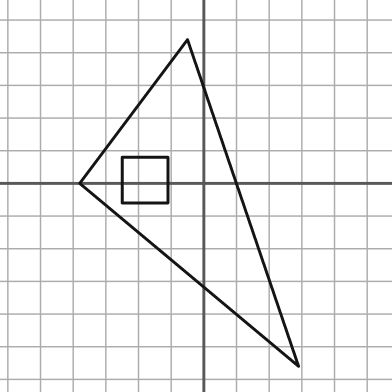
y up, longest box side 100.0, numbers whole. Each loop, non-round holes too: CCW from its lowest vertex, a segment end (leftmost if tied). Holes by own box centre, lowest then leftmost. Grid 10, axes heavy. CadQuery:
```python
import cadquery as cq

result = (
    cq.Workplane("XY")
    .moveTo(29.0, -56.0)
    .lineTo(-5.0, 44.0)
    .lineTo(-38.0, 0.0)
    .close()
    .moveTo(-25.0, -6.0)
    .lineTo(-11.0, -6.0)
    .lineTo(-11.0, 8.0)
    .lineTo(-25.0, 8.0)
    .close()
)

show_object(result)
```